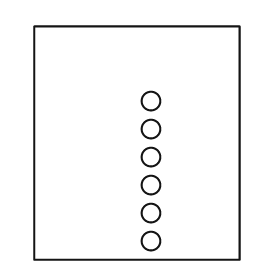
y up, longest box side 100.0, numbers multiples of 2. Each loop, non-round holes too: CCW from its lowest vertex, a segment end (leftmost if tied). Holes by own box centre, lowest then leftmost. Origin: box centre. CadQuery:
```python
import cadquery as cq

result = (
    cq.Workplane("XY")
    .moveTo(-44.0, -50.0)
    .lineTo(44.0, -50.0)
    .lineTo(44.0, 50.0)
    .lineTo(-44.0, 50.0)
    .close()
    .moveTo(6.0, -42.0)
    .circle(4.0)
    .moveTo(6.0, -30.0)
    .circle(4.0)
    .moveTo(6.0, -18.0)
    .circle(4.0)
    .moveTo(6.0, -6.0)
    .circle(4.0)
    .moveTo(6.0, 6.0)
    .circle(4.0)
    .moveTo(6.0, 18.0)
    .circle(4.0)
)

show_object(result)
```